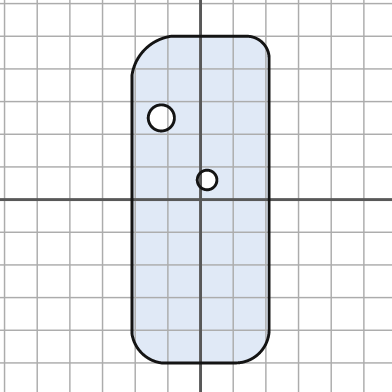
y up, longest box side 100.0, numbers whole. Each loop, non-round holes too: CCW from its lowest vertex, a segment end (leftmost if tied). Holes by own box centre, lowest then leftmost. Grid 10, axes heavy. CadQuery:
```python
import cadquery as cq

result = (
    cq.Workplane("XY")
    .moveTo(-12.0, -50.0)
    .lineTo(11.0, -50.0)
    .threePointArc((18.0, -47.0), (21.0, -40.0))
    .lineTo(21.0, 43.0)
    .threePointArc((19.0, 48.0), (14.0, 50.0))
    .lineTo(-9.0, 50.0)
    .threePointArc((-17.0, 46.0), (-21.0, 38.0))
    .lineTo(-21.0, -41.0)
    .threePointArc((-18.0, -47.0), (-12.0, -50.0))
    .close()
    .moveTo(2.0, 6.0)
    .circle(3.0)
    .moveTo(-12.0, 25.0)
    .circle(4.0)
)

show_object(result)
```